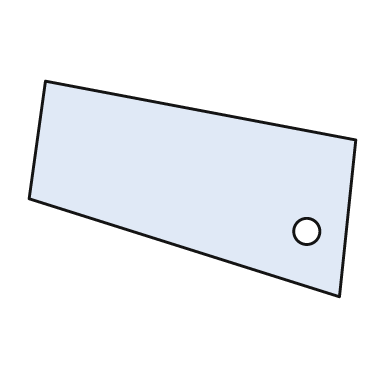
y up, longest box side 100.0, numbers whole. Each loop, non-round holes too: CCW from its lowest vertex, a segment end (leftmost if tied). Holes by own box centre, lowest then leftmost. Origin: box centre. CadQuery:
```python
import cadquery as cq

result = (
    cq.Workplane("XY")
    .moveTo(45.0, -33.0)
    .lineTo(50.0, 15.0)
    .lineTo(-45.0, 33.0)
    .lineTo(-50.0, -3.0)
    .close()
    .moveTo(35.0, -13.0)
    .circle(4.0)
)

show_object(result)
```